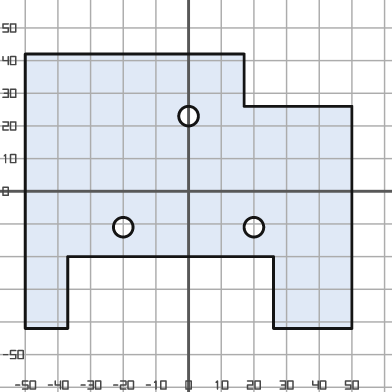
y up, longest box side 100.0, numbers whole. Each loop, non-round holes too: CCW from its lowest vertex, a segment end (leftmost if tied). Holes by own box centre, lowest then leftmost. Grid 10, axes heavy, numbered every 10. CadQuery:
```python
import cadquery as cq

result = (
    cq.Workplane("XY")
    .moveTo(-50.0, -42.0)
    .lineTo(-37.0, -42.0)
    .lineTo(-37.0, -20.0)
    .lineTo(26.0, -20.0)
    .lineTo(26.0, -42.0)
    .lineTo(50.0, -42.0)
    .lineTo(50.0, 26.0)
    .lineTo(17.0, 26.0)
    .lineTo(17.0, 42.0)
    .lineTo(-50.0, 42.0)
    .close()
    .moveTo(-20.0, -11.0)
    .circle(3.0)
    .moveTo(20.0, -11.0)
    .circle(3.0)
    .moveTo(0.0, 23.0)
    .circle(3.0)
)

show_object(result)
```